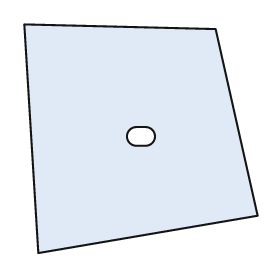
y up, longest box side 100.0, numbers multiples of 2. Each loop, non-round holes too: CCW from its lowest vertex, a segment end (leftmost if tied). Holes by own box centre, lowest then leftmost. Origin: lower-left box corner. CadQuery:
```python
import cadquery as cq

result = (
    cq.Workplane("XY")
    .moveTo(6.0, 0.0)
    .lineTo(100.0, 16.0)
    .lineTo(82.0, 96.0)
    .lineTo(0.0, 98.0)
    .close()
    .moveTo(48.0, 46.0)
    .lineTo(52.0, 46.0)
    .threePointArc((56.0, 50.0), (52.0, 54.0))
    .lineTo(48.0, 54.0)
    .threePointArc((44.0, 50.0), (48.0, 46.0))
    .close()
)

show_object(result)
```